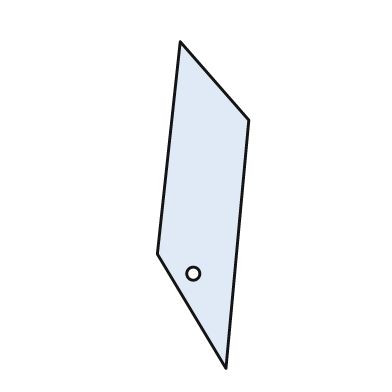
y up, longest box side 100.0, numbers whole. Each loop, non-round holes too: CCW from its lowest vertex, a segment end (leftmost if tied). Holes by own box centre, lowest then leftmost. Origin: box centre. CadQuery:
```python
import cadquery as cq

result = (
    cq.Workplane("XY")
    .moveTo(7.0, -50.0)
    .lineTo(14.0, 26.0)
    .lineTo(-7.0, 50.0)
    .lineTo(-14.0, -15.0)
    .close()
    .moveTo(-3.0, -21.0)
    .circle(2.0)
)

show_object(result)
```